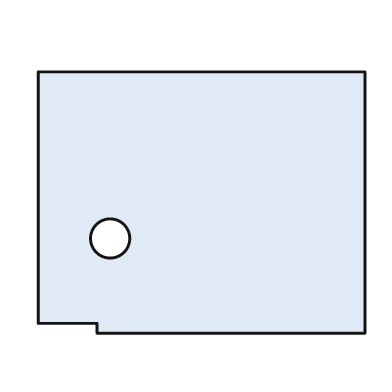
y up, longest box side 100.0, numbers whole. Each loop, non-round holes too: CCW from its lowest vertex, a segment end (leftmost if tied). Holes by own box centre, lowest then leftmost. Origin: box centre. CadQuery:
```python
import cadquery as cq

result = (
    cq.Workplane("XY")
    .moveTo(-32.0, -40.0)
    .lineTo(50.0, -40.0)
    .lineTo(50.0, 40.0)
    .lineTo(-50.0, 40.0)
    .lineTo(-50.0, -37.0)
    .lineTo(-32.0, -37.0)
    .close()
    .moveTo(-28.0, -11.0)
    .circle(6.0)
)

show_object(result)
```